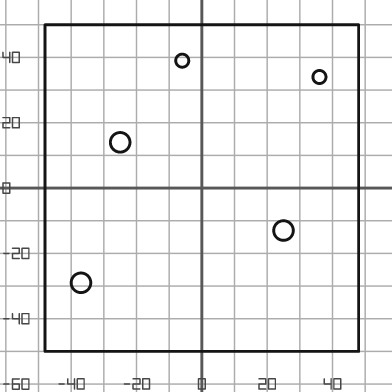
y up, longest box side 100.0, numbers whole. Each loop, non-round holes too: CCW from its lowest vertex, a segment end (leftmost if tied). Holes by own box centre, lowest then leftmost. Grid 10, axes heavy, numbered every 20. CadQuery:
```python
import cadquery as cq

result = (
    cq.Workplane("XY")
    .moveTo(-48.0, -50.0)
    .lineTo(48.0, -50.0)
    .lineTo(48.0, 50.0)
    .lineTo(-48.0, 50.0)
    .close()
    .moveTo(-37.0, -29.0)
    .circle(3.0)
    .moveTo(25.0, -13.0)
    .circle(3.0)
    .moveTo(-25.0, 14.0)
    .circle(3.0)
    .moveTo(36.0, 34.0)
    .circle(2.0)
    .moveTo(-6.0, 39.0)
    .circle(2.0)
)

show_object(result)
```